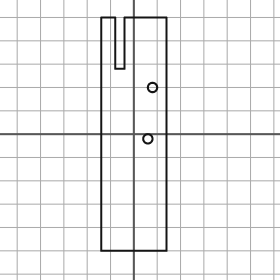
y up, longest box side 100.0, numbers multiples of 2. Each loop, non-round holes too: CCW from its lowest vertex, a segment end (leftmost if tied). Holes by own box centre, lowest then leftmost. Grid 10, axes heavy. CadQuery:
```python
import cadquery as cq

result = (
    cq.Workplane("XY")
    .moveTo(-14.0, -50.0)
    .lineTo(14.0, -50.0)
    .lineTo(14.0, 50.0)
    .lineTo(-4.0, 50.0)
    .lineTo(-4.0, 28.0)
    .lineTo(-8.0, 28.0)
    .lineTo(-8.0, 50.0)
    .lineTo(-14.0, 50.0)
    .close()
    .moveTo(6.0, -2.0)
    .circle(2.0)
    .moveTo(8.0, 20.0)
    .circle(2.0)
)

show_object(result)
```